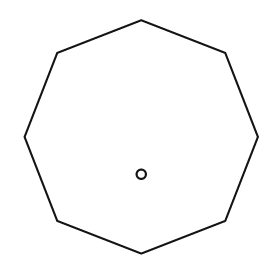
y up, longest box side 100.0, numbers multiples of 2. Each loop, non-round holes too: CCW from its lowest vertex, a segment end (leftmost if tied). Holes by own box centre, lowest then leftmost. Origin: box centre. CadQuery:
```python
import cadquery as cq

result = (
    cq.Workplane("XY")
    .moveTo(0.0, -50.0)
    .lineTo(36.0, -36.0)
    .lineTo(50.0, 0.0)
    .lineTo(36.0, 36.0)
    .lineTo(0.0, 50.0)
    .lineTo(-36.0, 36.0)
    .lineTo(-50.0, 0.0)
    .lineTo(-36.0, -36.0)
    .close()
    .moveTo(0.0, -16.0)
    .circle(2.0)
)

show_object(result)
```